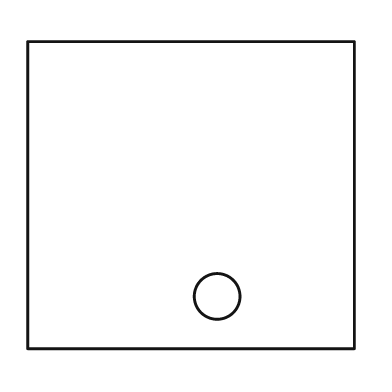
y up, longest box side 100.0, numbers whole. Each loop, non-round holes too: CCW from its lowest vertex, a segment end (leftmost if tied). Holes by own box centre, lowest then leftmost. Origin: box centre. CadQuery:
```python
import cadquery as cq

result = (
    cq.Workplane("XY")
    .moveTo(-50.0, -47.0)
    .lineTo(50.0, -47.0)
    .lineTo(50.0, 47.0)
    .lineTo(-50.0, 47.0)
    .close()
    .moveTo(8.0, -31.0)
    .circle(7.0)
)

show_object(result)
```